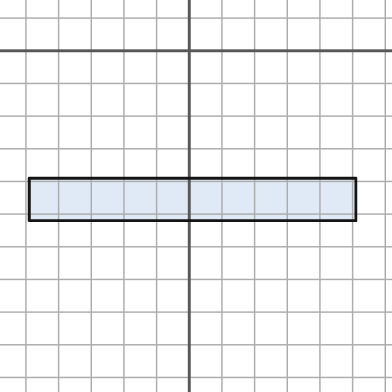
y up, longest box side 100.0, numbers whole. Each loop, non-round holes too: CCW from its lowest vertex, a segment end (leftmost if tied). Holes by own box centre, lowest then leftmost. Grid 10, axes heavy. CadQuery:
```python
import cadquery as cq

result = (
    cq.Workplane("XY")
    .moveTo(-49.0, -52.0)
    .lineTo(51.0, -52.0)
    .lineTo(51.0, -39.0)
    .lineTo(-49.0, -39.0)
    .close()
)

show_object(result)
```